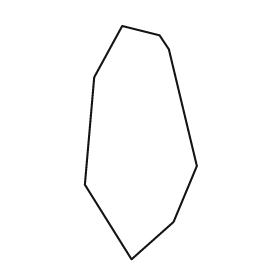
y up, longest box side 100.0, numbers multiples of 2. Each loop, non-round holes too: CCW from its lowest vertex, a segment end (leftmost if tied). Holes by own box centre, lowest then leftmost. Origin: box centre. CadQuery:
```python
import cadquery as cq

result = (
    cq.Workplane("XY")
    .moveTo(-4.0, -50.0)
    .lineTo(14.0, -34.0)
    .lineTo(24.0, -10.0)
    .lineTo(12.0, 40.0)
    .lineTo(8.0, 46.0)
    .lineTo(-8.0, 50.0)
    .lineTo(-20.0, 28.0)
    .lineTo(-24.0, -18.0)
    .close()
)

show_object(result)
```